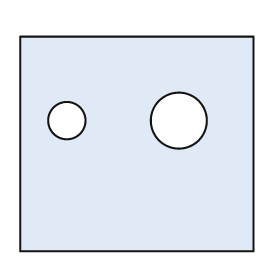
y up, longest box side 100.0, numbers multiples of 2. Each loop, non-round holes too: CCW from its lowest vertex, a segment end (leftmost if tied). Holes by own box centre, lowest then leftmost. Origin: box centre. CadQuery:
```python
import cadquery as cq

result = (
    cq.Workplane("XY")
    .moveTo(-50.0, -46.0)
    .lineTo(50.0, -46.0)
    .lineTo(50.0, 46.0)
    .lineTo(-50.0, 46.0)
    .close()
    .moveTo(-30.0, 10.0)
    .circle(8.0)
    .moveTo(18.0, 10.0)
    .circle(12.0)
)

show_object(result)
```